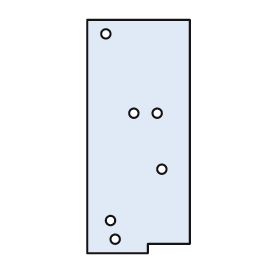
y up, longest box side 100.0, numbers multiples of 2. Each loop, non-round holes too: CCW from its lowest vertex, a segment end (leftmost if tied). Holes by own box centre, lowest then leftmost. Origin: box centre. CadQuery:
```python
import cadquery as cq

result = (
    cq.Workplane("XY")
    .moveTo(-22.0, -50.0)
    .lineTo(4.0, -50.0)
    .lineTo(4.0, -46.0)
    .lineTo(22.0, -46.0)
    .lineTo(22.0, 50.0)
    .lineTo(-22.0, 50.0)
    .close()
    .moveTo(-10.0, -44.0)
    .circle(2.0)
    .moveTo(-12.0, -36.0)
    .circle(2.0)
    .moveTo(10.0, -14.0)
    .circle(2.0)
    .moveTo(-2.0, 10.0)
    .circle(2.0)
    .moveTo(8.0, 10.0)
    .circle(2.0)
    .moveTo(-14.0, 44.0)
    .circle(2.0)
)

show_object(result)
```